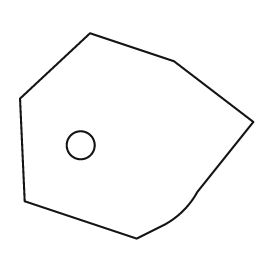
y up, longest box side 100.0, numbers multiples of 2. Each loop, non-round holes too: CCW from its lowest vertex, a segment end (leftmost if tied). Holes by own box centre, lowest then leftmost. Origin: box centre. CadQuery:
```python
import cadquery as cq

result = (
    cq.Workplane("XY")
    .moveTo(0.0, -44.0)
    .lineTo(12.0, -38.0)
    .threePointArc((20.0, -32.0), (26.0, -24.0))
    .lineTo(50.0, 6.0)
    .lineTo(16.0, 32.0)
    .lineTo(-20.0, 44.0)
    .lineTo(-50.0, 16.0)
    .lineTo(-48.0, -28.0)
    .close()
    .moveTo(-24.0, -4.0)
    .circle(6.0)
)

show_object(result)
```